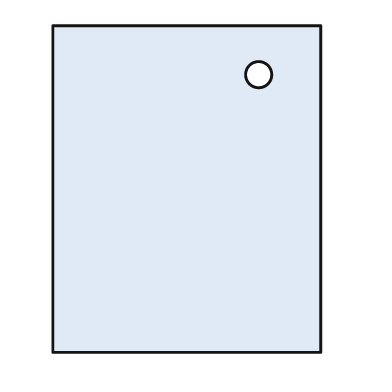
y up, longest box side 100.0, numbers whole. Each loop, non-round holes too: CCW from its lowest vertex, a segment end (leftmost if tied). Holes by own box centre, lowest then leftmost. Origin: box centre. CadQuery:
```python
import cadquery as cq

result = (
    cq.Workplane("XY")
    .moveTo(-41.0, -50.0)
    .lineTo(41.0, -50.0)
    .lineTo(41.0, 50.0)
    .lineTo(-41.0, 50.0)
    .close()
    .moveTo(22.0, 35.0)
    .circle(4.0)
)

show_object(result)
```